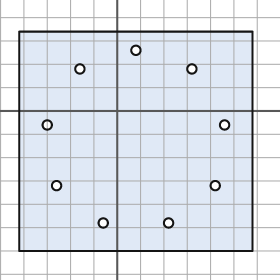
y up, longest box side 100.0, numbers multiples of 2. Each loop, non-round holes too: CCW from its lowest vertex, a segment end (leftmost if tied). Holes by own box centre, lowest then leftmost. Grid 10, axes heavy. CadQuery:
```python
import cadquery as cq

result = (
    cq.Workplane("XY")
    .moveTo(-42.0, -60.0)
    .lineTo(58.0, -60.0)
    .lineTo(58.0, 34.0)
    .lineTo(-42.0, 34.0)
    .close()
    .moveTo(-6.0, -48.0)
    .circle(2.0)
    .moveTo(22.0, -48.0)
    .circle(2.0)
    .moveTo(-26.0, -32.0)
    .circle(2.0)
    .moveTo(42.0, -32.0)
    .circle(2.0)
    .moveTo(-30.0, -6.0)
    .circle(2.0)
    .moveTo(46.0, -6.0)
    .circle(2.0)
    .moveTo(-16.0, 18.0)
    .circle(2.0)
    .moveTo(32.0, 18.0)
    .circle(2.0)
    .moveTo(8.0, 26.0)
    .circle(2.0)
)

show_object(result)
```